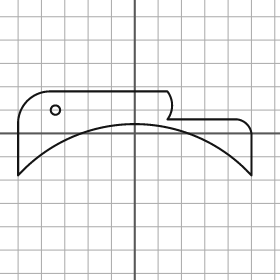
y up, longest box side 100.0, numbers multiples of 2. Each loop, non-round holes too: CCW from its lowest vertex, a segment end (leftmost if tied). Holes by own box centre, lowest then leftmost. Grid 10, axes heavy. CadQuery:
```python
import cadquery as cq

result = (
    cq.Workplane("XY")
    .moveTo(-50.0, -18.0)
    .threePointArc((0.0, 4.0), (50.0, -18.0))
    .lineTo(50.0, 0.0)
    .threePointArc((48.0, 4.0), (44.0, 6.0))
    .lineTo(14.0, 6.0)
    .threePointArc((16.0, 12.0), (14.0, 18.0))
    .lineTo(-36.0, 18.0)
    .threePointArc((-46.0, 14.0), (-50.0, 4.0))
    .close()
    .moveTo(-34.0, 10.0)
    .circle(2.0)
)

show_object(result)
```